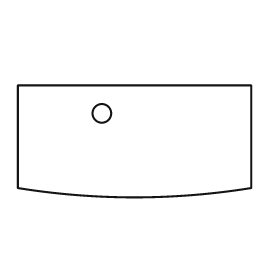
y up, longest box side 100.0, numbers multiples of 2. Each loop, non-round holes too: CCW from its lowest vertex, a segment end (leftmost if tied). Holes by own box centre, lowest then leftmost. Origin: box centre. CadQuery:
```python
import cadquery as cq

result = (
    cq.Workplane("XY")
    .moveTo(-50.0, -20.0)
    .threePointArc((0.0, -24.0), (50.0, -20.0))
    .lineTo(50.0, 24.0)
    .lineTo(-50.0, 24.0)
    .close()
    .moveTo(-14.0, 12.0)
    .circle(4.0)
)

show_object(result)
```